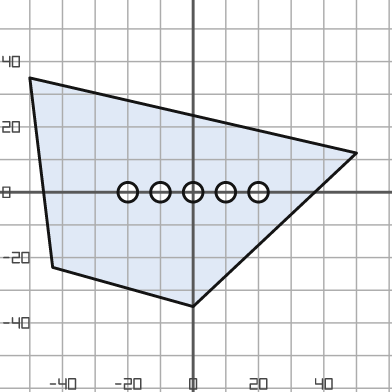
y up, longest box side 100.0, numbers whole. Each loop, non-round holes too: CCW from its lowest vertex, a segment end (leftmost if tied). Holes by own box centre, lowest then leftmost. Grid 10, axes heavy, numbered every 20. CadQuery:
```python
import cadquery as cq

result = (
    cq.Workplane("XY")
    .moveTo(0.0, -35.0)
    .lineTo(50.0, 12.0)
    .lineTo(-50.0, 35.0)
    .lineTo(-43.0, -23.0)
    .close()
    .moveTo(-20.0, 0.0)
    .circle(3.0)
    .moveTo(-10.0, 0.0)
    .circle(3.0)
    .moveTo(0.0, 0.0)
    .circle(3.0)
    .moveTo(10.0, 0.0)
    .circle(3.0)
    .moveTo(20.0, 0.0)
    .circle(3.0)
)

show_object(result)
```